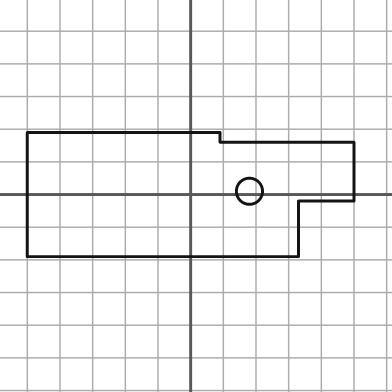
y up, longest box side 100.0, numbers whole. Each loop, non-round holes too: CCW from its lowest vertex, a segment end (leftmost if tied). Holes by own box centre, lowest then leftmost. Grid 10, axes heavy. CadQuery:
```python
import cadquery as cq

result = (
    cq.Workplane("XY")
    .moveTo(-50.0, -19.0)
    .lineTo(33.0, -19.0)
    .lineTo(33.0, -2.0)
    .lineTo(50.0, -2.0)
    .lineTo(50.0, 16.0)
    .lineTo(9.0, 16.0)
    .lineTo(9.0, 19.0)
    .lineTo(-50.0, 19.0)
    .close()
    .moveTo(18.0, 1.0)
    .circle(4.0)
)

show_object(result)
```